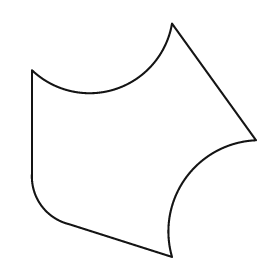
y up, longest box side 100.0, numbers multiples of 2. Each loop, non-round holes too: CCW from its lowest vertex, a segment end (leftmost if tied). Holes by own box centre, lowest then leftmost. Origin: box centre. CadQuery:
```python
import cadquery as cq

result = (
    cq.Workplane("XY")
    .moveTo(12.0, -50.0)
    .threePointArc((18.0, -16.0), (48.0, 0.0))
    .lineTo(12.0, 50.0)
    .threePointArc((-12.0, 22.0), (-48.0, 30.0))
    .lineTo(-48.0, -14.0)
    .threePointArc((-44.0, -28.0), (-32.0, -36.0))
    .close()
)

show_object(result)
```